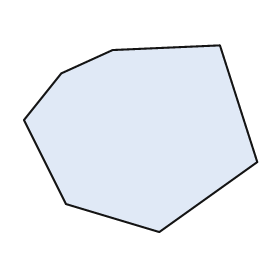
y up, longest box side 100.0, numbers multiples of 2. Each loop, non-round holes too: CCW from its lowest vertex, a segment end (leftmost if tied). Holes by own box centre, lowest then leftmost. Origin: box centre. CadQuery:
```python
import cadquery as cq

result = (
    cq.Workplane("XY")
    .moveTo(8.0, -40.0)
    .lineTo(50.0, -10.0)
    .lineTo(34.0, 40.0)
    .lineTo(-12.0, 38.0)
    .lineTo(-34.0, 28.0)
    .lineTo(-50.0, 8.0)
    .lineTo(-32.0, -28.0)
    .close()
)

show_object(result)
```